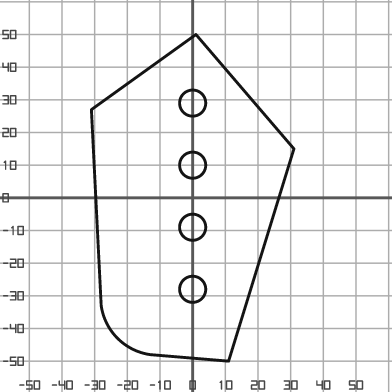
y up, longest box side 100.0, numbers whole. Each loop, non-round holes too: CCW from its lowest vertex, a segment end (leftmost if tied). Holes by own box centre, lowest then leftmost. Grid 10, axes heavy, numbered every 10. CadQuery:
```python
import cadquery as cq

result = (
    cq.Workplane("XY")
    .moveTo(11.0, -50.0)
    .lineTo(31.0, 15.0)
    .lineTo(1.0, 50.0)
    .lineTo(-31.0, 27.0)
    .lineTo(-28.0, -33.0)
    .threePointArc((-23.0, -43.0), (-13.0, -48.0))
    .close()
    .moveTo(0.0, -28.0)
    .circle(4.0)
    .moveTo(0.0, -9.0)
    .circle(4.0)
    .moveTo(0.0, 10.0)
    .circle(4.0)
    .moveTo(0.0, 29.0)
    .circle(4.0)
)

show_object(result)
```